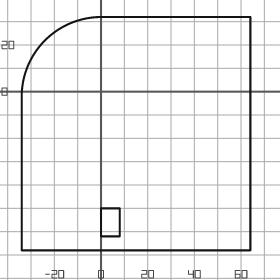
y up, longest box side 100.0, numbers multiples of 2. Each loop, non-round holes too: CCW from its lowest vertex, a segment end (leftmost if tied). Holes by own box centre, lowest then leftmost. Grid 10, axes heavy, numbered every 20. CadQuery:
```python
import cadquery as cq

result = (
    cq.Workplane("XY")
    .moveTo(-34.0, -68.0)
    .lineTo(64.0, -68.0)
    .lineTo(64.0, 32.0)
    .lineTo(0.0, 32.0)
    .threePointArc((-24.0, 22.0), (-34.0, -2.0))
    .close()
    .moveTo(0.0, -62.0)
    .lineTo(8.0, -62.0)
    .lineTo(8.0, -50.0)
    .lineTo(0.0, -50.0)
    .close()
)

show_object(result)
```